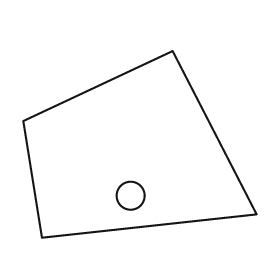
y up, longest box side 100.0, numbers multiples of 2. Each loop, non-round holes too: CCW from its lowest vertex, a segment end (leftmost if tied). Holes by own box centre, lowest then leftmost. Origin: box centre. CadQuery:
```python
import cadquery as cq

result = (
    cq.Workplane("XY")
    .moveTo(-42.0, -40.0)
    .lineTo(50.0, -30.0)
    .lineTo(14.0, 40.0)
    .lineTo(-50.0, 10.0)
    .close()
    .moveTo(-4.0, -22.0)
    .circle(6.0)
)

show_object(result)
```